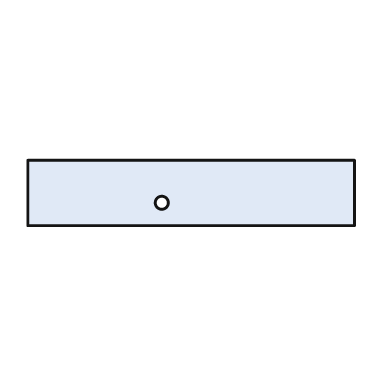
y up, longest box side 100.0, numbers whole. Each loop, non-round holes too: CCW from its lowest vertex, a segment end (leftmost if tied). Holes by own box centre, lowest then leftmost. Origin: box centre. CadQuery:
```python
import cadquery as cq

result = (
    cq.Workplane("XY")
    .moveTo(-50.0, -10.0)
    .lineTo(50.0, -10.0)
    .lineTo(50.0, 10.0)
    .lineTo(-50.0, 10.0)
    .close()
    .moveTo(-9.0, -3.0)
    .circle(2.0)
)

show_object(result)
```